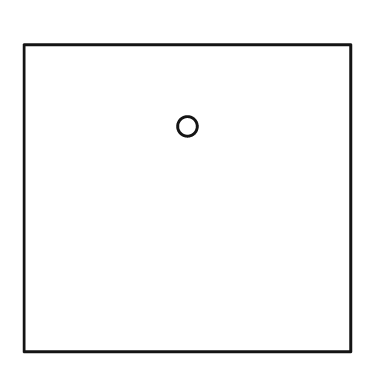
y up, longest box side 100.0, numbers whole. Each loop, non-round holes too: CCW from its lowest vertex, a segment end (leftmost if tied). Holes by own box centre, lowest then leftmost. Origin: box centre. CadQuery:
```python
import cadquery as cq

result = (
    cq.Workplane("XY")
    .moveTo(-50.0, -47.0)
    .lineTo(50.0, -47.0)
    .lineTo(50.0, 47.0)
    .lineTo(-50.0, 47.0)
    .close()
    .moveTo(0.0, 22.0)
    .circle(3.0)
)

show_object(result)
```